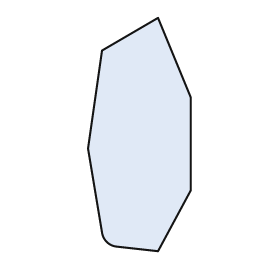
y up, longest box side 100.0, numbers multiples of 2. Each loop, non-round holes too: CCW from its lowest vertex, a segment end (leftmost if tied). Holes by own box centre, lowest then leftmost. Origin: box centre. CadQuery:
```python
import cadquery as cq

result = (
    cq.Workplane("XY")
    .moveTo(8.0, -50.0)
    .lineTo(22.0, -24.0)
    .lineTo(22.0, 16.0)
    .lineTo(8.0, 50.0)
    .lineTo(-16.0, 36.0)
    .lineTo(-22.0, -6.0)
    .lineTo(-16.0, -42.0)
    .threePointArc((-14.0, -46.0), (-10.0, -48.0))
    .close()
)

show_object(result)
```